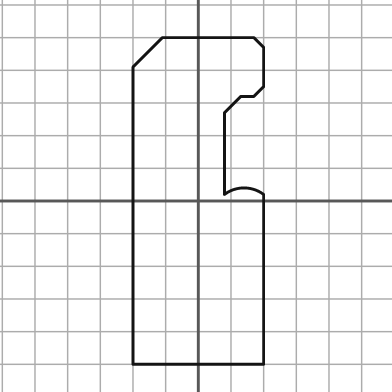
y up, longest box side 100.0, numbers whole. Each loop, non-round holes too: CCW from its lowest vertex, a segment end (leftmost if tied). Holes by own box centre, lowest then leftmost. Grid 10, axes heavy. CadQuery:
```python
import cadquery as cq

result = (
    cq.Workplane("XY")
    .moveTo(-20.0, -50.0)
    .lineTo(20.0, -50.0)
    .lineTo(20.0, 2.0)
    .threePointArc((14.0, 4.0), (8.0, 2.0))
    .lineTo(8.0, 27.0)
    .lineTo(13.0, 32.0)
    .lineTo(17.0, 32.0)
    .lineTo(20.0, 35.0)
    .lineTo(20.0, 47.0)
    .lineTo(17.0, 50.0)
    .lineTo(-11.0, 50.0)
    .lineTo(-20.0, 41.0)
    .close()
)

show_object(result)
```